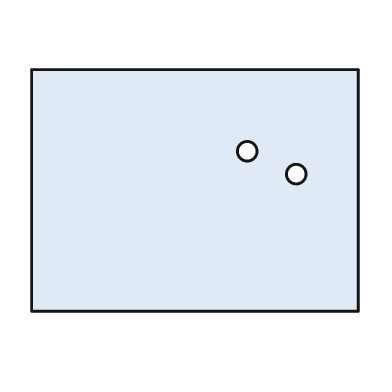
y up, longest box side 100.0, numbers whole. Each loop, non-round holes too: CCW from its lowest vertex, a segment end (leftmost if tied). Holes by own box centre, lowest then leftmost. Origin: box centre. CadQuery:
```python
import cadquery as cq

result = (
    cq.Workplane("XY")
    .moveTo(-50.0, -37.0)
    .lineTo(50.0, -37.0)
    .lineTo(50.0, 37.0)
    .lineTo(-50.0, 37.0)
    .close()
    .moveTo(31.0, 5.0)
    .circle(3.0)
    .moveTo(16.0, 12.0)
    .circle(3.0)
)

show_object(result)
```